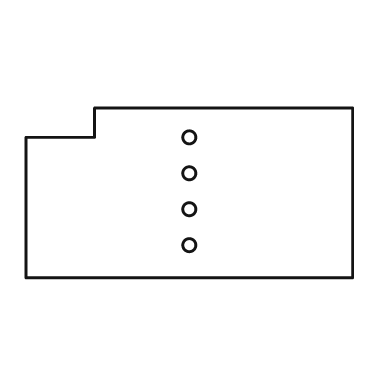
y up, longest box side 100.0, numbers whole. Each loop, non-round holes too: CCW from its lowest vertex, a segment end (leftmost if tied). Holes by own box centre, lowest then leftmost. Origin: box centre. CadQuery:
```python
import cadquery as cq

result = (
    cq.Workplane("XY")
    .moveTo(-50.0, -26.0)
    .lineTo(50.0, -26.0)
    .lineTo(50.0, 26.0)
    .lineTo(-29.0, 26.0)
    .lineTo(-29.0, 17.0)
    .lineTo(-50.0, 17.0)
    .close()
    .moveTo(0.0, -16.0)
    .circle(2.0)
    .moveTo(0.0, -5.0)
    .circle(2.0)
    .moveTo(0.0, 6.0)
    .circle(2.0)
    .moveTo(0.0, 17.0)
    .circle(2.0)
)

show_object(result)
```